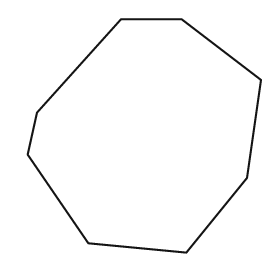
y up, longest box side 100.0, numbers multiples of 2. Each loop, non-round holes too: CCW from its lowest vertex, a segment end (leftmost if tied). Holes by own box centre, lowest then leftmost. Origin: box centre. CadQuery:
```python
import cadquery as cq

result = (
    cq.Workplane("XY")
    .moveTo(18.0, -50.0)
    .lineTo(44.0, -18.0)
    .lineTo(50.0, 24.0)
    .lineTo(16.0, 50.0)
    .lineTo(-10.0, 50.0)
    .lineTo(-46.0, 10.0)
    .lineTo(-50.0, -8.0)
    .lineTo(-24.0, -46.0)
    .close()
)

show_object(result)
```